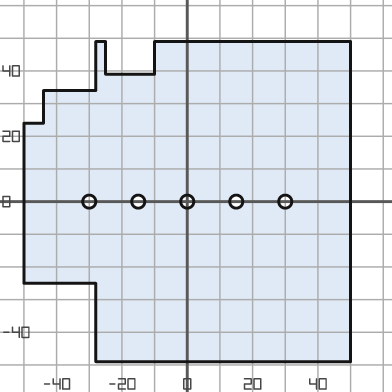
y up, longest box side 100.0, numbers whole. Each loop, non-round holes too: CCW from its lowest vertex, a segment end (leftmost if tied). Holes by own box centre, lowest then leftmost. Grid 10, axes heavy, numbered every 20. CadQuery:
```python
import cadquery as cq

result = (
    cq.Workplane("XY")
    .moveTo(-28.0, -49.0)
    .lineTo(50.0, -49.0)
    .lineTo(50.0, 49.0)
    .lineTo(-10.0, 49.0)
    .lineTo(-10.0, 39.0)
    .lineTo(-25.0, 39.0)
    .lineTo(-25.0, 49.0)
    .lineTo(-28.0, 49.0)
    .lineTo(-28.0, 34.0)
    .lineTo(-44.0, 34.0)
    .lineTo(-44.0, 24.0)
    .lineTo(-50.0, 24.0)
    .lineTo(-50.0, -25.0)
    .lineTo(-28.0, -25.0)
    .close()
    .moveTo(-30.0, 0.0)
    .circle(2.0)
    .moveTo(-15.0, 0.0)
    .circle(2.0)
    .moveTo(0.0, 0.0)
    .circle(2.0)
    .moveTo(15.0, 0.0)
    .circle(2.0)
    .moveTo(30.0, 0.0)
    .circle(2.0)
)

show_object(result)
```